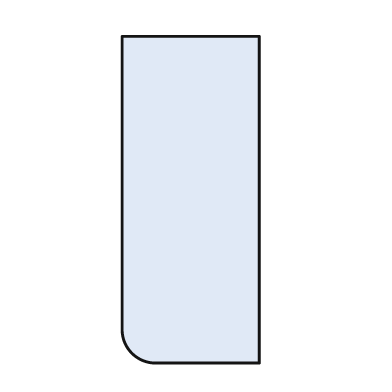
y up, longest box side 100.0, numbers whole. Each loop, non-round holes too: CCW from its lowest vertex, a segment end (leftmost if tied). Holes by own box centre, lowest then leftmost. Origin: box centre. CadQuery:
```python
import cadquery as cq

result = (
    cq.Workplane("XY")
    .moveTo(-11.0, -50.0)
    .lineTo(21.0, -50.0)
    .lineTo(21.0, 50.0)
    .lineTo(-21.0, 50.0)
    .lineTo(-21.0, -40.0)
    .threePointArc((-18.0, -47.0), (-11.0, -50.0))
    .close()
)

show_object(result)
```